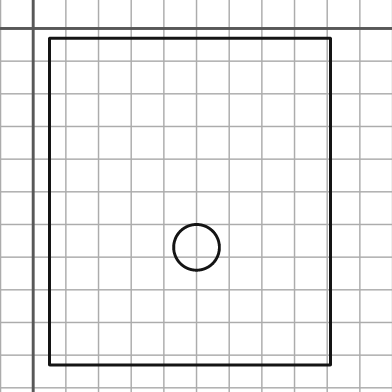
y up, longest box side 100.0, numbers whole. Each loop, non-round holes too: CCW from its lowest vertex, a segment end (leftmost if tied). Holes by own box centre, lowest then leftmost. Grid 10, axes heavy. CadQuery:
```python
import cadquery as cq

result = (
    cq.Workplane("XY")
    .moveTo(5.0, -103.0)
    .lineTo(91.0, -103.0)
    .lineTo(91.0, -3.0)
    .lineTo(5.0, -3.0)
    .close()
    .moveTo(50.0, -67.0)
    .circle(7.0)
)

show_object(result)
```